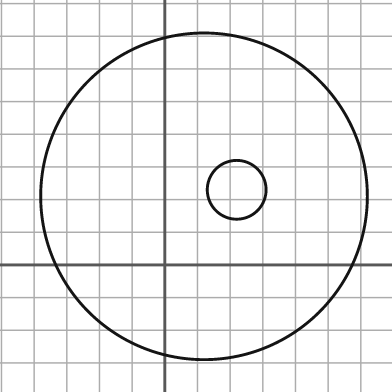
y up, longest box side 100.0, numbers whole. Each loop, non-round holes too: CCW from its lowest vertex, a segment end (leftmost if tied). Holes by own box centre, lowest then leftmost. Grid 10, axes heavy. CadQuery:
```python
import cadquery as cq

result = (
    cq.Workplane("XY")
    .moveTo(12.0, 21.0)
    .circle(50.0)
    .moveTo(22.0, 23.0)
    .circle(9.0)
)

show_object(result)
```